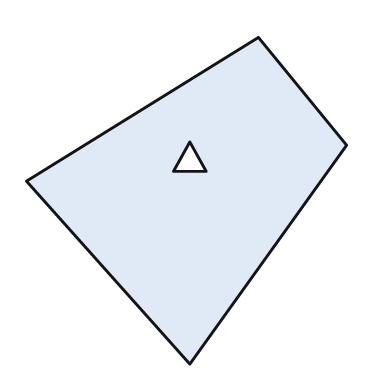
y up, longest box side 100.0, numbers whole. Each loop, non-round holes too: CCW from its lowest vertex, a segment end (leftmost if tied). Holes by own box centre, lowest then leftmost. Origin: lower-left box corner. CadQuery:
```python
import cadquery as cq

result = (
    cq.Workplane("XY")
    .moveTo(50.0, 0.0)
    .lineTo(98.0, 67.0)
    .lineTo(71.0, 100.0)
    .lineTo(0.0, 56.0)
    .close()
    .moveTo(45.0, 59.0)
    .lineTo(55.0, 59.0)
    .lineTo(50.0, 68.0)
    .close()
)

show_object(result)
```